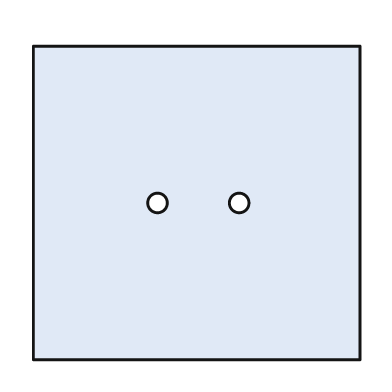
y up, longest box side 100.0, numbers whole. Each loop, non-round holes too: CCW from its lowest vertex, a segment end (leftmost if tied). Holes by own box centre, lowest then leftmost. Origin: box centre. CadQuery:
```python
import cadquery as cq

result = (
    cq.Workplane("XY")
    .moveTo(-50.0, -48.0)
    .lineTo(50.0, -48.0)
    .lineTo(50.0, 48.0)
    .lineTo(-50.0, 48.0)
    .close()
    .moveTo(-12.0, 0.0)
    .circle(3.0)
    .moveTo(13.0, 0.0)
    .circle(3.0)
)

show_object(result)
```